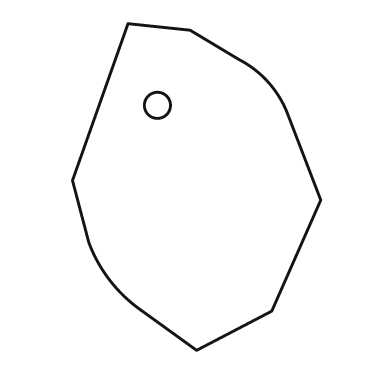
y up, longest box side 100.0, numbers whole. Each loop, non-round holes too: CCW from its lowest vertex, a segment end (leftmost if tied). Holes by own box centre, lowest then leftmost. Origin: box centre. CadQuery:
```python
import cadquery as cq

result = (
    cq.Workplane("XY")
    .moveTo(0.0, -50.0)
    .lineTo(23.0, -38.0)
    .lineTo(38.0, -4.0)
    .lineTo(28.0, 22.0)
    .threePointArc((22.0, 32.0), (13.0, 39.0))
    .lineTo(-2.0, 48.0)
    .lineTo(-21.0, 50.0)
    .lineTo(-38.0, 2.0)
    .lineTo(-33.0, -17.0)
    .threePointArc((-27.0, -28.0), (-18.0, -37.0))
    .close()
    .moveTo(-12.0, 25.0)
    .circle(4.0)
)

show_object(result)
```